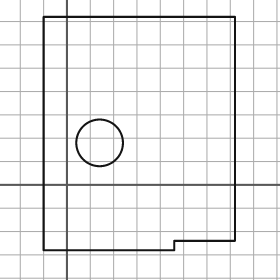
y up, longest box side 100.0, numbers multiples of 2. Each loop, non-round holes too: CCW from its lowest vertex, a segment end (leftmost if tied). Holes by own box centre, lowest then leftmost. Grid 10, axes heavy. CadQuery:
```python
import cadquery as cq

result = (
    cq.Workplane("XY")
    .moveTo(-10.0, -28.0)
    .lineTo(46.0, -28.0)
    .lineTo(46.0, -24.0)
    .lineTo(72.0, -24.0)
    .lineTo(72.0, 72.0)
    .lineTo(-10.0, 72.0)
    .close()
    .moveTo(14.0, 18.0)
    .circle(10.0)
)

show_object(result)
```